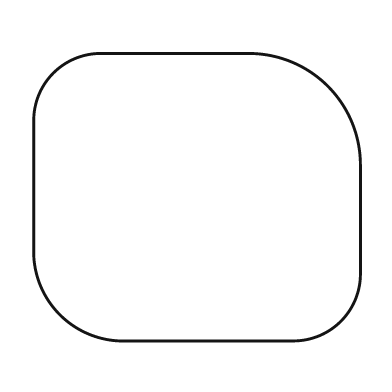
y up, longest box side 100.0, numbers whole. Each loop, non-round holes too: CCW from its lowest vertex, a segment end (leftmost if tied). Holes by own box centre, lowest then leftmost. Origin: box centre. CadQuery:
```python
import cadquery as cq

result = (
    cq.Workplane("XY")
    .moveTo(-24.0, -44.0)
    .lineTo(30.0, -44.0)
    .threePointArc((44.0, -38.0), (50.0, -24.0))
    .lineTo(50.0, 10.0)
    .threePointArc((40.0, 34.0), (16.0, 44.0))
    .lineTo(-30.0, 44.0)
    .threePointArc((-44.0, 38.0), (-50.0, 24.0))
    .lineTo(-50.0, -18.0)
    .threePointArc((-42.0, -36.0), (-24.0, -44.0))
    .close()
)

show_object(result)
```